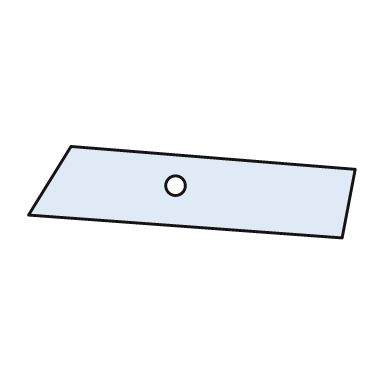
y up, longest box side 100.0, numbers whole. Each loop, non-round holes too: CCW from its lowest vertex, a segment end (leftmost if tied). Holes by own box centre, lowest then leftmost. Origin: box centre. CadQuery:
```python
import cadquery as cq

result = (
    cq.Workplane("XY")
    .moveTo(46.0, -14.0)
    .lineTo(50.0, 7.0)
    .lineTo(-37.0, 14.0)
    .lineTo(-50.0, -7.0)
    .close()
    .moveTo(-5.0, 2.0)
    .circle(3.0)
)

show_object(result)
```